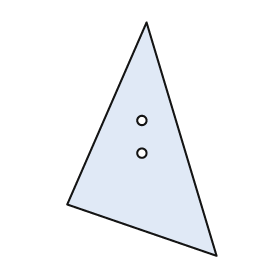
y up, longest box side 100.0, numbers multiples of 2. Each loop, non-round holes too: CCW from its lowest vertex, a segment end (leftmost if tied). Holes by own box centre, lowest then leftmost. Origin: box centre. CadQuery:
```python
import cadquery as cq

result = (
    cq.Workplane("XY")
    .moveTo(32.0, -50.0)
    .lineTo(2.0, 50.0)
    .lineTo(-32.0, -28.0)
    .close()
    .moveTo(0.0, -6.0)
    .circle(2.0)
    .moveTo(0.0, 8.0)
    .circle(2.0)
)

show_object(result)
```